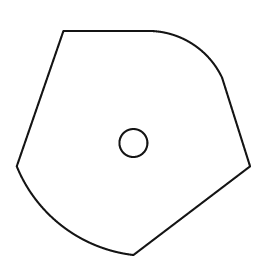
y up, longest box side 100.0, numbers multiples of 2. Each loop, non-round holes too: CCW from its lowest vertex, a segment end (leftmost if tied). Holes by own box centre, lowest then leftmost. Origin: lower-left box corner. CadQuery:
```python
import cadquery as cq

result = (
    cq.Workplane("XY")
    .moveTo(50.0, 0.0)
    .lineTo(100.0, 38.0)
    .lineTo(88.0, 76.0)
    .threePointArc((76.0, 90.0), (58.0, 96.0))
    .lineTo(20.0, 96.0)
    .lineTo(0.0, 38.0)
    .threePointArc((20.0, 12.0), (50.0, 0.0))
    .close()
    .moveTo(50.0, 48.0)
    .circle(6.0)
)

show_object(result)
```